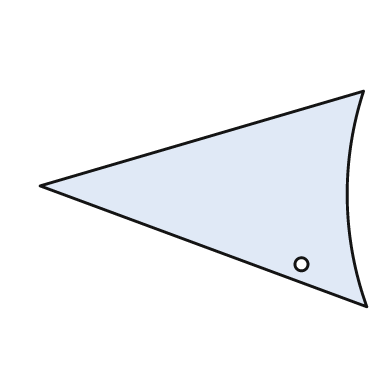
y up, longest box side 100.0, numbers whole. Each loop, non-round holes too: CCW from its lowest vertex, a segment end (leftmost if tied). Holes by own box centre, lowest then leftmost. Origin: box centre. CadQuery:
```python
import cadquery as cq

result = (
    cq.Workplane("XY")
    .moveTo(50.0, -33.0)
    .threePointArc((44.0, 0.0), (49.0, 33.0))
    .lineTo(-50.0, 4.0)
    .close()
    .moveTo(30.0, -20.0)
    .circle(2.0)
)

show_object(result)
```